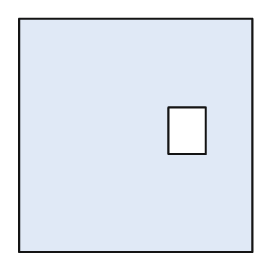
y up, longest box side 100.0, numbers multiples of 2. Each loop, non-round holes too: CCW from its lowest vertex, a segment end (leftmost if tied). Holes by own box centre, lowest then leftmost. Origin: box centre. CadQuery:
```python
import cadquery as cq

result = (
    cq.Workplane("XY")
    .moveTo(-50.0, -50.0)
    .lineTo(50.0, -50.0)
    .lineTo(50.0, 50.0)
    .lineTo(-50.0, 50.0)
    .close()
    .moveTo(14.0, -8.0)
    .lineTo(30.0, -8.0)
    .lineTo(30.0, 12.0)
    .lineTo(14.0, 12.0)
    .close()
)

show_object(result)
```